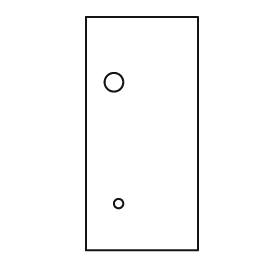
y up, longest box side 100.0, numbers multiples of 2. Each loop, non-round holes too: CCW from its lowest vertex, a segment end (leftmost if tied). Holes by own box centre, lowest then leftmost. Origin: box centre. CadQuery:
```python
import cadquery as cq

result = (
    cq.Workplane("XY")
    .moveTo(-24.0, -50.0)
    .lineTo(24.0, -50.0)
    .lineTo(24.0, 50.0)
    .lineTo(-24.0, 50.0)
    .close()
    .moveTo(-10.0, -30.0)
    .circle(2.0)
    .moveTo(-12.0, 22.0)
    .circle(4.0)
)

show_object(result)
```